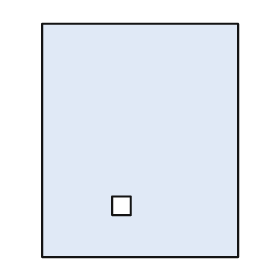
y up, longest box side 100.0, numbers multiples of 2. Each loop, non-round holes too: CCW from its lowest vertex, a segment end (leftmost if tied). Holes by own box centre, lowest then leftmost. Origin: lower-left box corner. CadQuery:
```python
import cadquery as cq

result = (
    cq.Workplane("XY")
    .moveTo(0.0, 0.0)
    .lineTo(84.0, 0.0)
    .lineTo(84.0, 100.0)
    .lineTo(0.0, 100.0)
    .close()
    .moveTo(30.0, 18.0)
    .lineTo(38.0, 18.0)
    .lineTo(38.0, 26.0)
    .lineTo(30.0, 26.0)
    .close()
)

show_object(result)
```